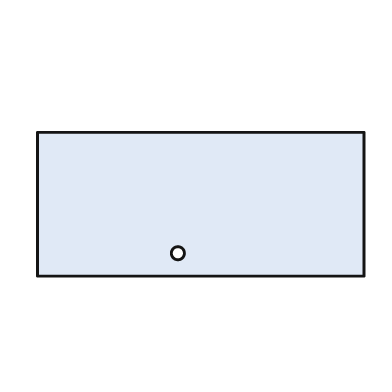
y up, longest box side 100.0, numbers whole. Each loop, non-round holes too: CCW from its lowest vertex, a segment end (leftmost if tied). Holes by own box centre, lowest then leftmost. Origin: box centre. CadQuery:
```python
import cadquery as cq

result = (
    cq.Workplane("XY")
    .moveTo(-50.0, -22.0)
    .lineTo(50.0, -22.0)
    .lineTo(50.0, 22.0)
    .lineTo(-50.0, 22.0)
    .close()
    .moveTo(-7.0, -15.0)
    .circle(2.0)
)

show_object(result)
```